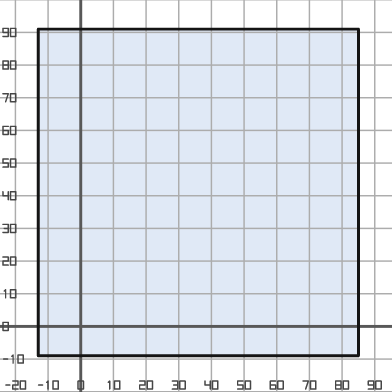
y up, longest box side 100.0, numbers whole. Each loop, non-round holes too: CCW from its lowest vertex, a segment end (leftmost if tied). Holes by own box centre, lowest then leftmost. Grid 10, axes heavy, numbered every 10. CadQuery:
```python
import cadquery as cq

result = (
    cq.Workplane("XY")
    .moveTo(-13.0, -9.0)
    .lineTo(85.0, -9.0)
    .lineTo(85.0, 91.0)
    .lineTo(-13.0, 91.0)
    .close()
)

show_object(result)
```